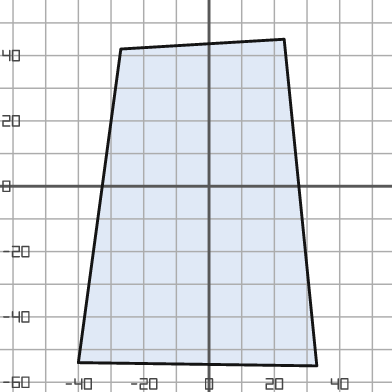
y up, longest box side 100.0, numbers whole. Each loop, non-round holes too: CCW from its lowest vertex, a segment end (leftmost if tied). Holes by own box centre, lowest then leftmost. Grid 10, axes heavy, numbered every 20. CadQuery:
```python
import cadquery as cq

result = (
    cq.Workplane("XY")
    .moveTo(33.0, -55.0)
    .lineTo(23.0, 45.0)
    .lineTo(-27.0, 42.0)
    .lineTo(-40.0, -54.0)
    .close()
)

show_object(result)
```